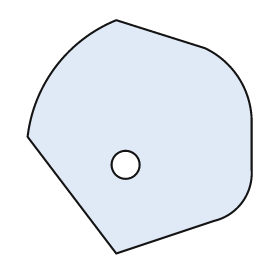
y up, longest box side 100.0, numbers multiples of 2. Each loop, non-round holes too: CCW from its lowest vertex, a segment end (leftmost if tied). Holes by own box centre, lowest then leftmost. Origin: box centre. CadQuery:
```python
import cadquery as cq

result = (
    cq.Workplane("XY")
    .moveTo(-10.0, -50.0)
    .lineTo(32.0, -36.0)
    .threePointArc((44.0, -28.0), (48.0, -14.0))
    .lineTo(48.0, 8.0)
    .threePointArc((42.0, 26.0), (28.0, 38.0))
    .lineTo(-10.0, 50.0)
    .threePointArc((-36.0, 30.0), (-48.0, 0.0))
    .close()
    .moveTo(-6.0, -12.0)
    .circle(6.0)
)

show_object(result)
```